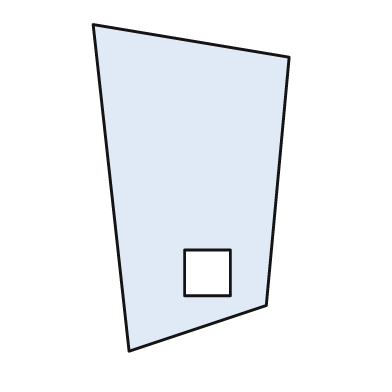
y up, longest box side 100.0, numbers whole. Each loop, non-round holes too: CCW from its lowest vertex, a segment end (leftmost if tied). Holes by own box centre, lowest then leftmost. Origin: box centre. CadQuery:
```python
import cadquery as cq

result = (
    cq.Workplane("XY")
    .moveTo(-19.0, -50.0)
    .lineTo(23.0, -36.0)
    .lineTo(30.0, 40.0)
    .lineTo(-30.0, 50.0)
    .close()
    .moveTo(-2.0, -33.0)
    .lineTo(12.0, -33.0)
    .lineTo(12.0, -19.0)
    .lineTo(-2.0, -19.0)
    .close()
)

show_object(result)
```